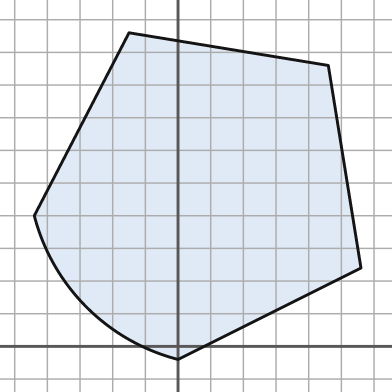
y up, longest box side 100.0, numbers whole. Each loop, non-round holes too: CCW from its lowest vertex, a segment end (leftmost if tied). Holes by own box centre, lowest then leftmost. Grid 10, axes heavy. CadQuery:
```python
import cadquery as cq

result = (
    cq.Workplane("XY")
    .moveTo(0.0, -4.0)
    .lineTo(56.0, 24.0)
    .lineTo(46.0, 86.0)
    .lineTo(-15.0, 96.0)
    .lineTo(-44.0, 40.0)
    .threePointArc((-28.0, 12.0), (0.0, -4.0))
    .close()
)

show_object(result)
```